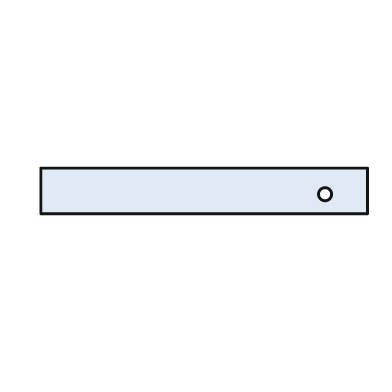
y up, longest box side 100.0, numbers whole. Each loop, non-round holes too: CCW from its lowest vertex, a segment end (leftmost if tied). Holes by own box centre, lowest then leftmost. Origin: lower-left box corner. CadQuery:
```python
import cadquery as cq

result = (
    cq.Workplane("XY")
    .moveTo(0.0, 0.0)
    .lineTo(100.0, 0.0)
    .lineTo(100.0, 14.0)
    .lineTo(0.0, 14.0)
    .close()
    .moveTo(87.0, 6.0)
    .circle(2.0)
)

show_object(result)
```